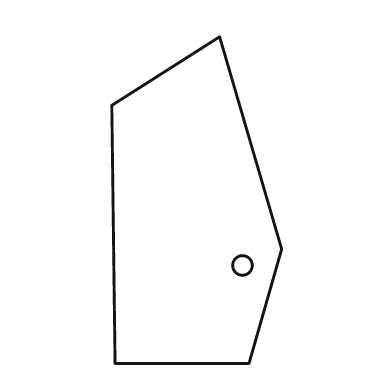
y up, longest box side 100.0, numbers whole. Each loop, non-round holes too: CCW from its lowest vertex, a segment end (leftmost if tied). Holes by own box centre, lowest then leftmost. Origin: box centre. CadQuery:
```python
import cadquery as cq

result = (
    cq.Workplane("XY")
    .moveTo(-25.0, -50.0)
    .lineTo(16.0, -50.0)
    .lineTo(26.0, -15.0)
    .lineTo(7.0, 50.0)
    .lineTo(-26.0, 29.0)
    .close()
    .moveTo(14.0, -20.0)
    .circle(3.0)
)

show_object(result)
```